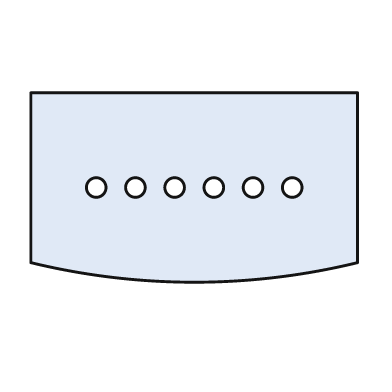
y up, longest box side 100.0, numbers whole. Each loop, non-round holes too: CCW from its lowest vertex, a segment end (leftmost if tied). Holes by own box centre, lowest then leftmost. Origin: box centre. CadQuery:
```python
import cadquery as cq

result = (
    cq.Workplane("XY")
    .moveTo(-50.0, -23.0)
    .threePointArc((0.0, -29.0), (50.0, -23.0))
    .lineTo(50.0, 29.0)
    .lineTo(-50.0, 29.0)
    .close()
    .moveTo(-30.0, 0.0)
    .circle(3.0)
    .moveTo(-18.0, 0.0)
    .circle(3.0)
    .moveTo(-6.0, 0.0)
    .circle(3.0)
    .moveTo(6.0, 0.0)
    .circle(3.0)
    .moveTo(18.0, 0.0)
    .circle(3.0)
    .moveTo(30.0, 0.0)
    .circle(3.0)
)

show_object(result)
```